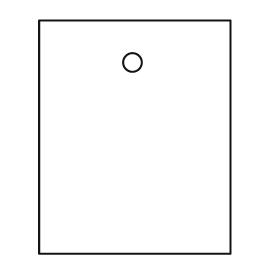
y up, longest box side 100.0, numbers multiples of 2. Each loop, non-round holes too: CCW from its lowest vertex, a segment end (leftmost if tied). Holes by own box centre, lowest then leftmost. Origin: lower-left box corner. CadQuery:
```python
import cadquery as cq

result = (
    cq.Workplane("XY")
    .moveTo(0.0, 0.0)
    .lineTo(82.0, 0.0)
    .lineTo(82.0, 100.0)
    .lineTo(0.0, 100.0)
    .close()
    .moveTo(40.0, 82.0)
    .circle(4.0)
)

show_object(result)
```